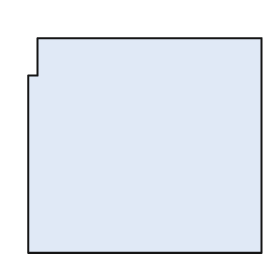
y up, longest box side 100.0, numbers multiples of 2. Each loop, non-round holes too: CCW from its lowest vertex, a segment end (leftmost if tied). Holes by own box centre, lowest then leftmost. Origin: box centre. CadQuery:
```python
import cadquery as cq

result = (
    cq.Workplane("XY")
    .moveTo(-50.0, -46.0)
    .lineTo(50.0, -46.0)
    .lineTo(50.0, 46.0)
    .lineTo(-46.0, 46.0)
    .lineTo(-46.0, 30.0)
    .lineTo(-50.0, 30.0)
    .close()
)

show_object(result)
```